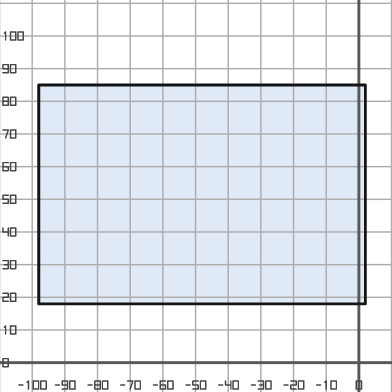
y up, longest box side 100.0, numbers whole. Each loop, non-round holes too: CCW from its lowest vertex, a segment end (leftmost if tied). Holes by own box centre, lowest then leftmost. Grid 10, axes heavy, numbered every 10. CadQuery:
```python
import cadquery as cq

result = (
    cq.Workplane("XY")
    .moveTo(-98.0, 18.0)
    .lineTo(2.0, 18.0)
    .lineTo(2.0, 85.0)
    .lineTo(-98.0, 85.0)
    .close()
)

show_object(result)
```